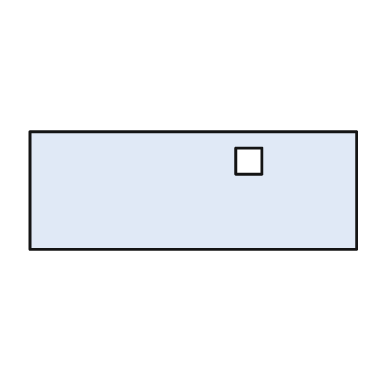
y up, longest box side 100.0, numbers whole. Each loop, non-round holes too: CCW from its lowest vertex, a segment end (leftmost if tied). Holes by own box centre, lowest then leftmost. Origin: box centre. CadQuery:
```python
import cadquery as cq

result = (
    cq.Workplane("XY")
    .moveTo(-50.0, -18.0)
    .lineTo(50.0, -18.0)
    .lineTo(50.0, 18.0)
    .lineTo(-50.0, 18.0)
    .close()
    .moveTo(13.0, 5.0)
    .lineTo(21.0, 5.0)
    .lineTo(21.0, 13.0)
    .lineTo(13.0, 13.0)
    .close()
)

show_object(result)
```